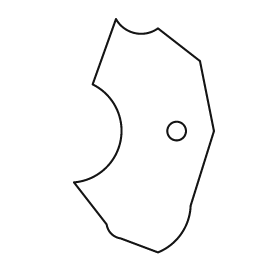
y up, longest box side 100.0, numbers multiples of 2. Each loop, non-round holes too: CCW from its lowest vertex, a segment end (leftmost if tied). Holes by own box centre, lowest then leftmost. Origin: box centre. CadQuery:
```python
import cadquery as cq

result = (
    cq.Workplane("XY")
    .moveTo(6.0, -50.0)
    .threePointArc((16.0, -42.0), (20.0, -30.0))
    .lineTo(30.0, 2.0)
    .lineTo(24.0, 32.0)
    .lineTo(6.0, 46.0)
    .threePointArc((-4.0, 44.0), (-12.0, 50.0))
    .lineTo(-22.0, 22.0)
    .threePointArc((-10.0, -2.0), (-30.0, -20.0))
    .lineTo(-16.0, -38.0)
    .threePointArc((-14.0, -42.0), (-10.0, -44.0))
    .close()
    .moveTo(14.0, 2.0)
    .circle(4.0)
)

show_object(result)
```